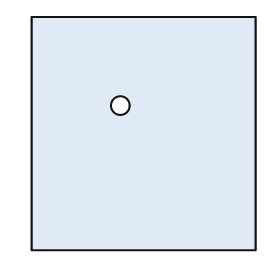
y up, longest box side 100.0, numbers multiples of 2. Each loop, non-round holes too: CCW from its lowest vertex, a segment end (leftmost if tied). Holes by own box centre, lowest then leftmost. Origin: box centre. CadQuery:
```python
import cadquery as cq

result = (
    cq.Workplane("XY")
    .moveTo(-48.0, -50.0)
    .lineTo(48.0, -50.0)
    .lineTo(48.0, 50.0)
    .lineTo(-48.0, 50.0)
    .close()
    .moveTo(-10.0, 12.0)
    .circle(4.0)
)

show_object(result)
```